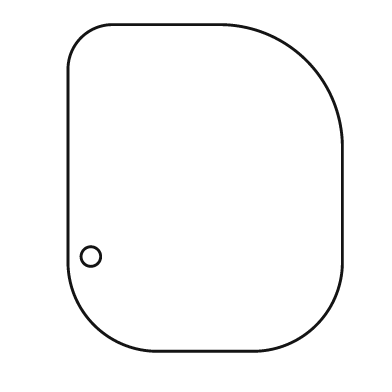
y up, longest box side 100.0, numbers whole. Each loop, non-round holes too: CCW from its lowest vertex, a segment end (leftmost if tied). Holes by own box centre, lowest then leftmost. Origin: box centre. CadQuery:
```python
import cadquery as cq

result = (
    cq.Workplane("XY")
    .moveTo(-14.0, -50.0)
    .lineTo(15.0, -50.0)
    .threePointArc((34.0, -42.0), (42.0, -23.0))
    .lineTo(42.0, 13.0)
    .threePointArc((31.0, 39.0), (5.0, 50.0))
    .lineTo(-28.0, 50.0)
    .threePointArc((-38.0, 46.0), (-42.0, 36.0))
    .lineTo(-42.0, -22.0)
    .threePointArc((-34.0, -42.0), (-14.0, -50.0))
    .close()
    .moveTo(-35.0, -21.0)
    .circle(3.0)
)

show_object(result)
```